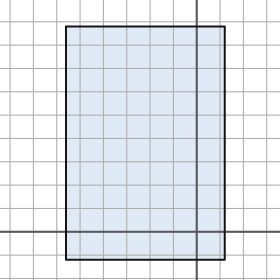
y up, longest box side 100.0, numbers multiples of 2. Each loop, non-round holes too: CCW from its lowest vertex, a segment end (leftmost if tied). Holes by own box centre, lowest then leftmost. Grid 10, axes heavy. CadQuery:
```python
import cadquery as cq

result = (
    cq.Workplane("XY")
    .moveTo(-56.0, -12.0)
    .lineTo(12.0, -12.0)
    .lineTo(12.0, 88.0)
    .lineTo(-56.0, 88.0)
    .close()
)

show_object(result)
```